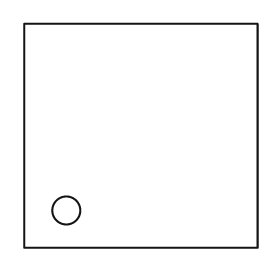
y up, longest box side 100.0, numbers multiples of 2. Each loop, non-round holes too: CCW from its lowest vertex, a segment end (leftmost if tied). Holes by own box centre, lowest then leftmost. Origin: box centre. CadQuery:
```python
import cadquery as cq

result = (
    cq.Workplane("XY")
    .moveTo(-50.0, -48.0)
    .lineTo(50.0, -48.0)
    .lineTo(50.0, 48.0)
    .lineTo(-50.0, 48.0)
    .close()
    .moveTo(-32.0, -32.0)
    .circle(6.0)
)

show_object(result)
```